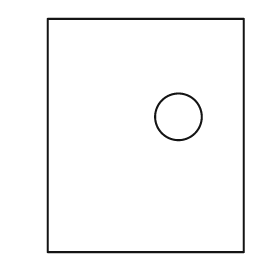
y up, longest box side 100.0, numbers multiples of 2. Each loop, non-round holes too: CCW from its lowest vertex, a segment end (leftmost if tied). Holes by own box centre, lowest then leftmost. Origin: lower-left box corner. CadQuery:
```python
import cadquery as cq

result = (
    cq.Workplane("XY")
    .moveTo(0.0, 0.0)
    .lineTo(84.0, 0.0)
    .lineTo(84.0, 100.0)
    .lineTo(0.0, 100.0)
    .close()
    .moveTo(56.0, 58.0)
    .circle(10.0)
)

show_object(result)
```